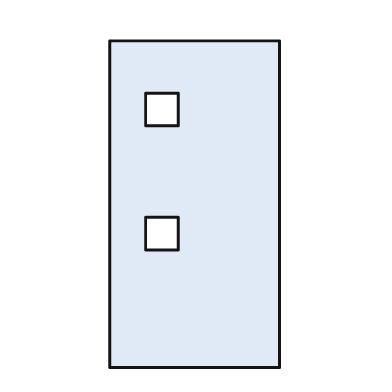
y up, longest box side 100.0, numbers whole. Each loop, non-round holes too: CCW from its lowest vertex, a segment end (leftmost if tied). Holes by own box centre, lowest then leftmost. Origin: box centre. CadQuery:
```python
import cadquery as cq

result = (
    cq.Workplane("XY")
    .moveTo(-26.0, -50.0)
    .lineTo(26.0, -50.0)
    .lineTo(26.0, 50.0)
    .lineTo(-26.0, 50.0)
    .close()
    .moveTo(-15.0, -14.0)
    .lineTo(-5.0, -14.0)
    .lineTo(-5.0, -4.0)
    .lineTo(-15.0, -4.0)
    .close()
    .moveTo(-15.0, 24.0)
    .lineTo(-5.0, 24.0)
    .lineTo(-5.0, 34.0)
    .lineTo(-15.0, 34.0)
    .close()
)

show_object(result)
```